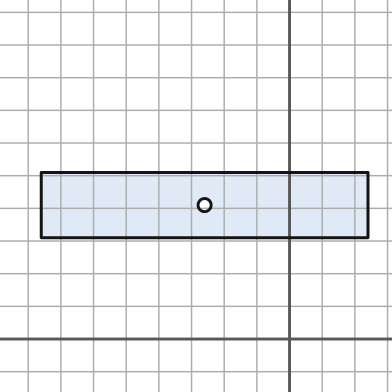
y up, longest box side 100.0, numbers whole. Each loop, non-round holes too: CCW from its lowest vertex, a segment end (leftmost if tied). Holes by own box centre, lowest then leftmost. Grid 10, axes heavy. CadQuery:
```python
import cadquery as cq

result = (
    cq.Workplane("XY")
    .moveTo(-76.0, 31.0)
    .lineTo(24.0, 31.0)
    .lineTo(24.0, 51.0)
    .lineTo(-76.0, 51.0)
    .close()
    .moveTo(-26.0, 41.0)
    .circle(2.0)
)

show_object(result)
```